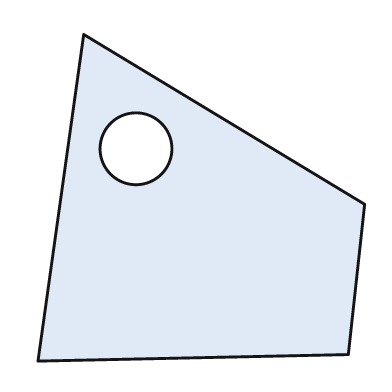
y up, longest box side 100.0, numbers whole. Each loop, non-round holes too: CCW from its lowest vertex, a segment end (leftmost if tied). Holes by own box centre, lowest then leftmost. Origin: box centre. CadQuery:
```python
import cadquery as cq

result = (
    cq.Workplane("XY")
    .moveTo(-50.0, -50.0)
    .lineTo(45.0, -48.0)
    .lineTo(50.0, -2.0)
    .lineTo(-36.0, 50.0)
    .close()
    .moveTo(-20.0, 15.0)
    .circle(11.0)
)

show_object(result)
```